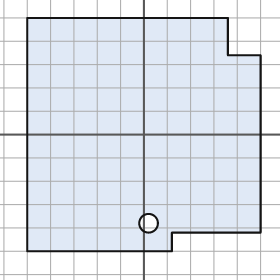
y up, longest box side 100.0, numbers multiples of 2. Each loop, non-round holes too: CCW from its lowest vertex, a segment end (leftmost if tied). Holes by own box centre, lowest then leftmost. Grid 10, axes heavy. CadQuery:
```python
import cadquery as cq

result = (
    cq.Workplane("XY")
    .moveTo(-50.0, -50.0)
    .lineTo(12.0, -50.0)
    .lineTo(12.0, -42.0)
    .lineTo(50.0, -42.0)
    .lineTo(50.0, 34.0)
    .lineTo(36.0, 34.0)
    .lineTo(36.0, 50.0)
    .lineTo(-50.0, 50.0)
    .close()
    .moveTo(2.0, -38.0)
    .circle(4.0)
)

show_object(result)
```